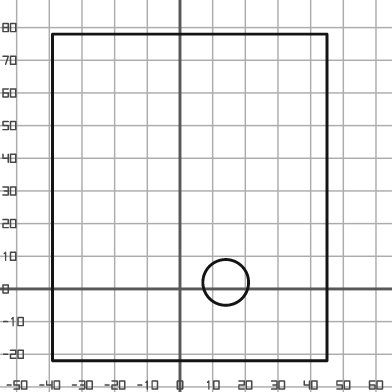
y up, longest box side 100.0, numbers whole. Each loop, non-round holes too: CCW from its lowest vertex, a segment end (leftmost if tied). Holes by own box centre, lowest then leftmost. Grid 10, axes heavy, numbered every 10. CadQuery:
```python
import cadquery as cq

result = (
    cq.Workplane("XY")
    .moveTo(-39.0, -22.0)
    .lineTo(45.0, -22.0)
    .lineTo(45.0, 78.0)
    .lineTo(-39.0, 78.0)
    .close()
    .moveTo(14.0, 2.0)
    .circle(7.0)
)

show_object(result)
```